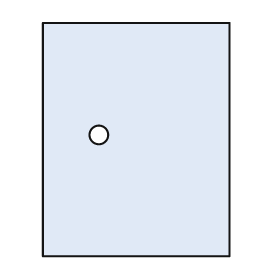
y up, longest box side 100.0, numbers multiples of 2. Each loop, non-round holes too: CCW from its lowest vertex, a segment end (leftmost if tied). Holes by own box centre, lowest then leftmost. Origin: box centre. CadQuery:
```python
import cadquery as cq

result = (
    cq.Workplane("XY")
    .moveTo(-40.0, -50.0)
    .lineTo(40.0, -50.0)
    .lineTo(40.0, 50.0)
    .lineTo(-40.0, 50.0)
    .close()
    .moveTo(-16.0, 2.0)
    .circle(4.0)
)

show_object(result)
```